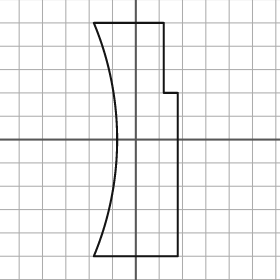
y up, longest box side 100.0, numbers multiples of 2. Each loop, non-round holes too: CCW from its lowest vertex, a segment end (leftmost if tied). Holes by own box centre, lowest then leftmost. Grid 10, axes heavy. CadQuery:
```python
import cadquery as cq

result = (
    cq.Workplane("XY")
    .moveTo(-18.0, -50.0)
    .lineTo(18.0, -50.0)
    .lineTo(18.0, 20.0)
    .lineTo(12.0, 20.0)
    .lineTo(12.0, 50.0)
    .lineTo(-18.0, 50.0)
    .threePointArc((-8.0, 0.0), (-18.0, -50.0))
    .close()
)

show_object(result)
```